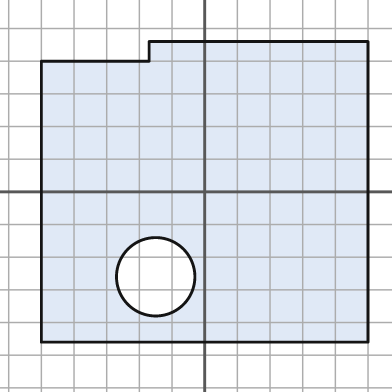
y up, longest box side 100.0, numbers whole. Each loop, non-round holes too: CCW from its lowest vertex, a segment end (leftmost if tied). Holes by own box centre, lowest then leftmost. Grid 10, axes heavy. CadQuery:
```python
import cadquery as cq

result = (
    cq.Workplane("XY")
    .moveTo(-50.0, -46.0)
    .lineTo(50.0, -46.0)
    .lineTo(50.0, 46.0)
    .lineTo(-17.0, 46.0)
    .lineTo(-17.0, 40.0)
    .lineTo(-50.0, 40.0)
    .close()
    .moveTo(-15.0, -26.0)
    .circle(12.0)
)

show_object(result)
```